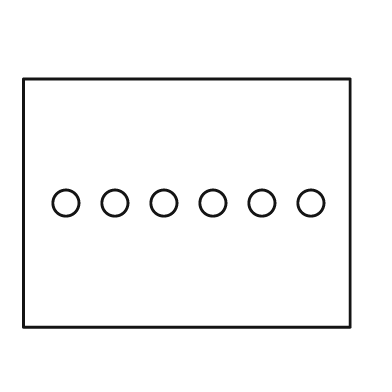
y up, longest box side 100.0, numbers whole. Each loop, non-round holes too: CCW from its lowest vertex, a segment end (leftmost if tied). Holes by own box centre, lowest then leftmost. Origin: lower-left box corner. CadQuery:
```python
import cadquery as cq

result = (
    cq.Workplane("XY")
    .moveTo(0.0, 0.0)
    .lineTo(100.0, 0.0)
    .lineTo(100.0, 76.0)
    .lineTo(0.0, 76.0)
    .close()
    .moveTo(13.0, 38.0)
    .circle(4.0)
    .moveTo(28.0, 38.0)
    .circle(4.0)
    .moveTo(43.0, 38.0)
    .circle(4.0)
    .moveTo(58.0, 38.0)
    .circle(4.0)
    .moveTo(73.0, 38.0)
    .circle(4.0)
    .moveTo(88.0, 38.0)
    .circle(4.0)
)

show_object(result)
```